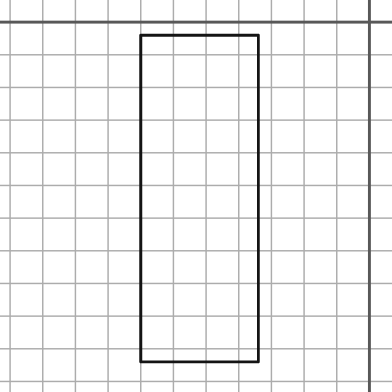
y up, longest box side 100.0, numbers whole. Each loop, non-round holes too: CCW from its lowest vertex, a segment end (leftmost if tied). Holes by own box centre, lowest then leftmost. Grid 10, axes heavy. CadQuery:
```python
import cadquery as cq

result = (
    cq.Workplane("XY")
    .moveTo(-70.0, -104.0)
    .lineTo(-34.0, -104.0)
    .lineTo(-34.0, -4.0)
    .lineTo(-70.0, -4.0)
    .close()
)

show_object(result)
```